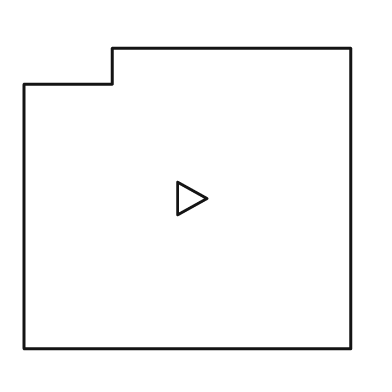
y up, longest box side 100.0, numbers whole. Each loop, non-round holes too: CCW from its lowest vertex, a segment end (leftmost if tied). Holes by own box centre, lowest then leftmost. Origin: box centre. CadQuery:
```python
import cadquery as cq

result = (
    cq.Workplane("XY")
    .moveTo(-50.0, -46.0)
    .lineTo(50.0, -46.0)
    .lineTo(50.0, 46.0)
    .lineTo(-23.0, 46.0)
    .lineTo(-23.0, 35.0)
    .lineTo(-50.0, 35.0)
    .close()
    .moveTo(-3.0, -5.0)
    .lineTo(6.0, 0.0)
    .lineTo(-3.0, 5.0)
    .close()
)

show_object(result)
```